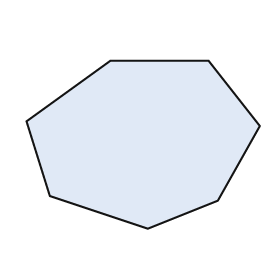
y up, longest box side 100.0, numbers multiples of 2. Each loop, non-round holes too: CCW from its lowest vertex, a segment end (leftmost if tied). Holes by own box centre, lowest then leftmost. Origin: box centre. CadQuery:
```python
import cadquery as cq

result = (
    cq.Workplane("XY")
    .moveTo(2.0, -36.0)
    .lineTo(32.0, -24.0)
    .lineTo(50.0, 8.0)
    .lineTo(28.0, 36.0)
    .lineTo(-14.0, 36.0)
    .lineTo(-50.0, 10.0)
    .lineTo(-40.0, -22.0)
    .close()
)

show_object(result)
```